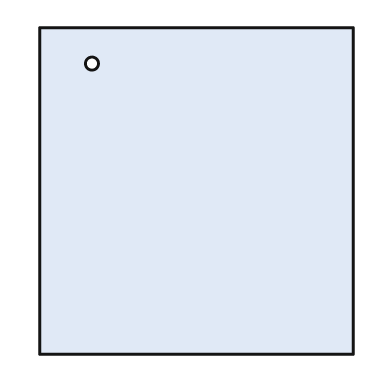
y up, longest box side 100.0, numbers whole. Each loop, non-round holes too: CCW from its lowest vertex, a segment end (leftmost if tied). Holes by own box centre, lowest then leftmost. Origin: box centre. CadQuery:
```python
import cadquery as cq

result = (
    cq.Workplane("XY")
    .moveTo(-48.0, -50.0)
    .lineTo(48.0, -50.0)
    .lineTo(48.0, 50.0)
    .lineTo(-48.0, 50.0)
    .close()
    .moveTo(-32.0, 39.0)
    .circle(2.0)
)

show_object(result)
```